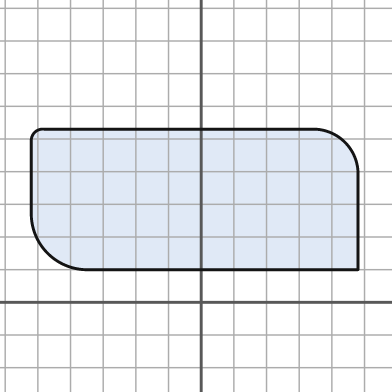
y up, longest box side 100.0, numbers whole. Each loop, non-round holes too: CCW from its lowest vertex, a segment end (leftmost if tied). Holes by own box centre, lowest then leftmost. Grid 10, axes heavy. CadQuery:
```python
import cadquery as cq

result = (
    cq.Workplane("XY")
    .moveTo(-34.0, 10.0)
    .lineTo(48.0, 10.0)
    .lineTo(48.0, 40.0)
    .threePointArc((44.0, 49.0), (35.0, 53.0))
    .lineTo(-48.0, 53.0)
    .threePointArc((-51.0, 52.0), (-52.0, 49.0))
    .lineTo(-52.0, 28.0)
    .threePointArc((-47.0, 15.0), (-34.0, 10.0))
    .close()
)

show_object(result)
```